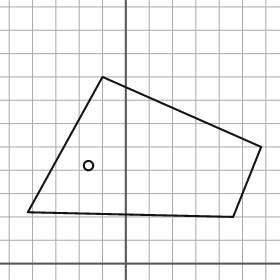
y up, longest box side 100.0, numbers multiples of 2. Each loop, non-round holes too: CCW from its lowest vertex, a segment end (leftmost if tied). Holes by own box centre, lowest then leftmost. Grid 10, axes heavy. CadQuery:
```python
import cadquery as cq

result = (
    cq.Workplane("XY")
    .moveTo(46.0, 20.0)
    .lineTo(58.0, 50.0)
    .lineTo(-10.0, 80.0)
    .lineTo(-42.0, 22.0)
    .close()
    .moveTo(-16.0, 42.0)
    .circle(2.0)
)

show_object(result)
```